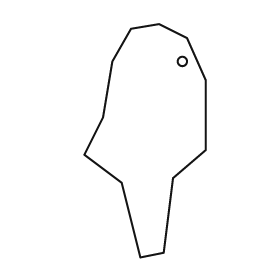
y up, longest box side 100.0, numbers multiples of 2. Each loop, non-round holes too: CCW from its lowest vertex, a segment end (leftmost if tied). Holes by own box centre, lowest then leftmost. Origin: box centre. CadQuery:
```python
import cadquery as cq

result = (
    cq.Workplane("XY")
    .moveTo(-2.0, -50.0)
    .lineTo(8.0, -48.0)
    .lineTo(12.0, -16.0)
    .lineTo(26.0, -4.0)
    .lineTo(26.0, 26.0)
    .lineTo(18.0, 44.0)
    .lineTo(6.0, 50.0)
    .lineTo(-6.0, 48.0)
    .lineTo(-14.0, 34.0)
    .lineTo(-18.0, 10.0)
    .lineTo(-26.0, -6.0)
    .lineTo(-10.0, -18.0)
    .close()
    .moveTo(16.0, 34.0)
    .circle(2.0)
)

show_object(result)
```